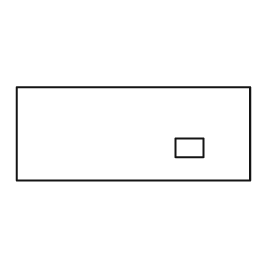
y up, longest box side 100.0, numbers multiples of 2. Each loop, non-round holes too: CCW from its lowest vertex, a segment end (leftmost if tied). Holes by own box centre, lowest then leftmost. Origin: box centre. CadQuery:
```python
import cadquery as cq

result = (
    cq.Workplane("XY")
    .moveTo(-50.0, -20.0)
    .lineTo(50.0, -20.0)
    .lineTo(50.0, 20.0)
    .lineTo(-50.0, 20.0)
    .close()
    .moveTo(18.0, -10.0)
    .lineTo(30.0, -10.0)
    .lineTo(30.0, -2.0)
    .lineTo(18.0, -2.0)
    .close()
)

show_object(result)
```